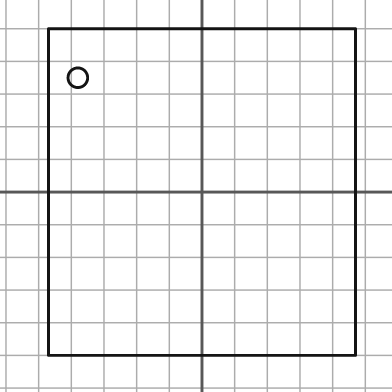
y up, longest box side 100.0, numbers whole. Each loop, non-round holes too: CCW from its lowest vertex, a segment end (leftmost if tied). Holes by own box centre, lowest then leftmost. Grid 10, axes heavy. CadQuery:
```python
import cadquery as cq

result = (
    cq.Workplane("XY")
    .moveTo(-47.0, -50.0)
    .lineTo(47.0, -50.0)
    .lineTo(47.0, 50.0)
    .lineTo(-47.0, 50.0)
    .close()
    .moveTo(-38.0, 35.0)
    .circle(3.0)
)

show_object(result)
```